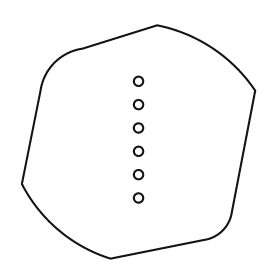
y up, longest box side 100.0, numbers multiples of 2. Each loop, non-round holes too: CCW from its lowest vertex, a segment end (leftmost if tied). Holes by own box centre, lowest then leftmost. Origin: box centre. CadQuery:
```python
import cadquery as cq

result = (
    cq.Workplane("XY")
    .moveTo(-12.0, -50.0)
    .lineTo(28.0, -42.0)
    .threePointArc((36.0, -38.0), (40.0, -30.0))
    .lineTo(50.0, 22.0)
    .threePointArc((32.0, 40.0), (8.0, 50.0))
    .lineTo(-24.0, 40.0)
    .threePointArc((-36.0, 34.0), (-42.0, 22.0))
    .lineTo(-50.0, -18.0)
    .threePointArc((-34.0, -38.0), (-12.0, -50.0))
    .close()
    .moveTo(0.0, -24.0)
    .circle(2.0)
    .moveTo(0.0, -14.0)
    .circle(2.0)
    .moveTo(0.0, -4.0)
    .circle(2.0)
    .moveTo(0.0, 6.0)
    .circle(2.0)
    .moveTo(0.0, 16.0)
    .circle(2.0)
    .moveTo(0.0, 26.0)
    .circle(2.0)
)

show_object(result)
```